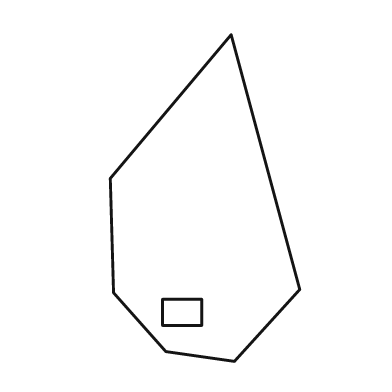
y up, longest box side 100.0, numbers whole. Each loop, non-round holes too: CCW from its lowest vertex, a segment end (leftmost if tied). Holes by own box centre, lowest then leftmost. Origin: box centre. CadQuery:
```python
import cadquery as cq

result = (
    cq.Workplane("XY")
    .moveTo(9.0, -50.0)
    .lineTo(29.0, -28.0)
    .lineTo(8.0, 50.0)
    .lineTo(-29.0, 6.0)
    .lineTo(-28.0, -29.0)
    .lineTo(-12.0, -47.0)
    .close()
    .moveTo(-13.0, -39.0)
    .lineTo(-1.0, -39.0)
    .lineTo(-1.0, -31.0)
    .lineTo(-13.0, -31.0)
    .close()
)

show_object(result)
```